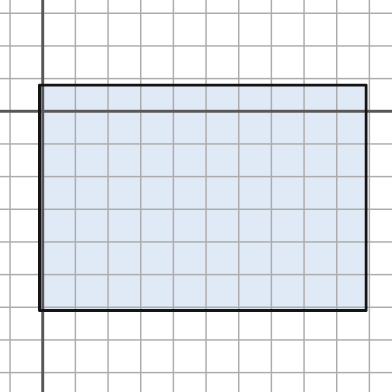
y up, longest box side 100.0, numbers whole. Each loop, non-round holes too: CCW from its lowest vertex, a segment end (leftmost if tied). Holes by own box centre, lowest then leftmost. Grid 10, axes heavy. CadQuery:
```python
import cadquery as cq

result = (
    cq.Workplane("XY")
    .moveTo(-1.0, -61.0)
    .lineTo(99.0, -61.0)
    .lineTo(99.0, 8.0)
    .lineTo(-1.0, 8.0)
    .close()
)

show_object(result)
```